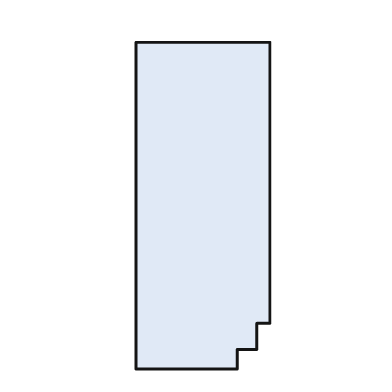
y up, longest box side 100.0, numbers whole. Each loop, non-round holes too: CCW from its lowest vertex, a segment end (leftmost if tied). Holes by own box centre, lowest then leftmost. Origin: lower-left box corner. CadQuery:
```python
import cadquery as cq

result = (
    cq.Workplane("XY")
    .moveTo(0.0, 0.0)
    .lineTo(31.0, 0.0)
    .lineTo(31.0, 6.0)
    .lineTo(37.0, 6.0)
    .lineTo(37.0, 14.0)
    .lineTo(41.0, 14.0)
    .lineTo(41.0, 100.0)
    .lineTo(0.0, 100.0)
    .close()
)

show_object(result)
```